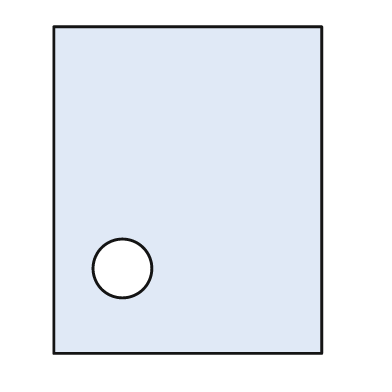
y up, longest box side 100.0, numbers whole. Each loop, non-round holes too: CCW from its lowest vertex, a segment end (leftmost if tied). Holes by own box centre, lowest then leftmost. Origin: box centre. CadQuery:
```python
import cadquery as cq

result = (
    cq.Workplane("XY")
    .moveTo(-41.0, -50.0)
    .lineTo(41.0, -50.0)
    .lineTo(41.0, 50.0)
    .lineTo(-41.0, 50.0)
    .close()
    .moveTo(-20.0, -24.0)
    .circle(9.0)
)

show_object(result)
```